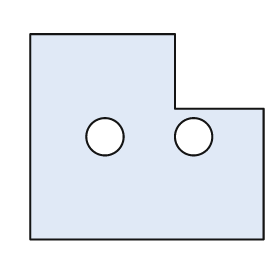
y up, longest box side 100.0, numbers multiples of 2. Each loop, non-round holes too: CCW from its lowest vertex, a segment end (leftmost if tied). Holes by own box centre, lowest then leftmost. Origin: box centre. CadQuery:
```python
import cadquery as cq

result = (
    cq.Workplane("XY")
    .moveTo(-50.0, -44.0)
    .lineTo(50.0, -44.0)
    .lineTo(50.0, 12.0)
    .lineTo(12.0, 12.0)
    .lineTo(12.0, 44.0)
    .lineTo(-50.0, 44.0)
    .close()
    .moveTo(-18.0, 0.0)
    .circle(8.0)
    .moveTo(20.0, 0.0)
    .circle(8.0)
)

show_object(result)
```